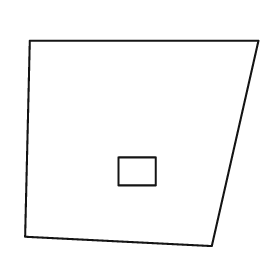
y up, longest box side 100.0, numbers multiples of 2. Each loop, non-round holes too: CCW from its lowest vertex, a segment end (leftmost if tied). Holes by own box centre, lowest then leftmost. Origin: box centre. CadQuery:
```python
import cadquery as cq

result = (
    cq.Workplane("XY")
    .moveTo(30.0, -44.0)
    .lineTo(50.0, 44.0)
    .lineTo(-48.0, 44.0)
    .lineTo(-50.0, -40.0)
    .close()
    .moveTo(-10.0, -18.0)
    .lineTo(6.0, -18.0)
    .lineTo(6.0, -6.0)
    .lineTo(-10.0, -6.0)
    .close()
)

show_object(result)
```